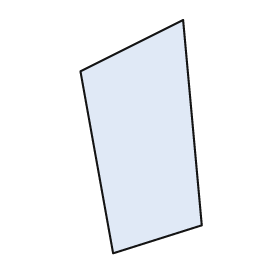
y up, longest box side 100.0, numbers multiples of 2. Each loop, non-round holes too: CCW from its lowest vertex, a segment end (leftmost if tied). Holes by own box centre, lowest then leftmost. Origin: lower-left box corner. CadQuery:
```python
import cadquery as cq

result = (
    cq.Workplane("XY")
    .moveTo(14.0, 0.0)
    .lineTo(52.0, 12.0)
    .lineTo(44.0, 100.0)
    .lineTo(0.0, 78.0)
    .close()
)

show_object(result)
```